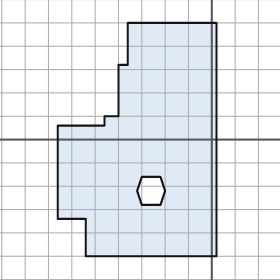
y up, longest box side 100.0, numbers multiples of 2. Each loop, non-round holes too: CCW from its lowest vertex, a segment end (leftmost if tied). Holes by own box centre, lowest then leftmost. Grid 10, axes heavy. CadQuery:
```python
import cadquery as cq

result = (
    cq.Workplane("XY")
    .moveTo(-54.0, -50.0)
    .lineTo(2.0, -50.0)
    .lineTo(2.0, 50.0)
    .lineTo(-36.0, 50.0)
    .lineTo(-36.0, 32.0)
    .lineTo(-40.0, 32.0)
    .lineTo(-40.0, 10.0)
    .lineTo(-46.0, 10.0)
    .lineTo(-46.0, 6.0)
    .lineTo(-66.0, 6.0)
    .lineTo(-66.0, -34.0)
    .lineTo(-54.0, -34.0)
    .close()
    .moveTo(-30.0, -28.0)
    .lineTo(-22.0, -28.0)
    .lineTo(-20.0, -22.0)
    .lineTo(-22.0, -16.0)
    .lineTo(-30.0, -16.0)
    .lineTo(-32.0, -22.0)
    .close()
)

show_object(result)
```